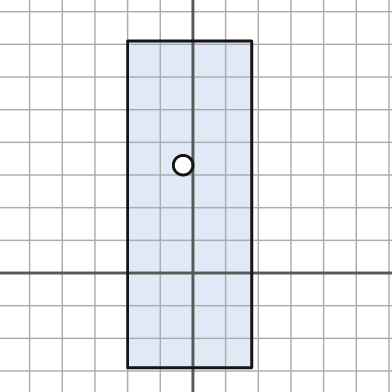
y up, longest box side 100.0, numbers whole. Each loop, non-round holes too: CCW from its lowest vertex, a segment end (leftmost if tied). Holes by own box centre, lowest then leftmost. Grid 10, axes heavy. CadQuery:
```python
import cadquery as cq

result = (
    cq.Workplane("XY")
    .moveTo(-20.0, -29.0)
    .lineTo(18.0, -29.0)
    .lineTo(18.0, 71.0)
    .lineTo(-20.0, 71.0)
    .close()
    .moveTo(-3.0, 33.0)
    .circle(3.0)
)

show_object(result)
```